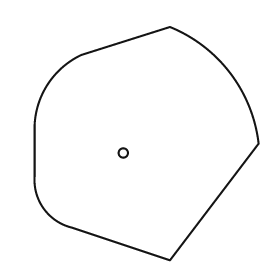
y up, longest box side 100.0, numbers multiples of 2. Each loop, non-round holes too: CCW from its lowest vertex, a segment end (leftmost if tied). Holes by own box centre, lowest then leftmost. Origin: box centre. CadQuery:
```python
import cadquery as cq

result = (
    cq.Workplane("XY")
    .moveTo(10.0, -50.0)
    .lineTo(48.0, 0.0)
    .threePointArc((36.0, 30.0), (10.0, 50.0))
    .lineTo(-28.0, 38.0)
    .threePointArc((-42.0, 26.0), (-48.0, 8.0))
    .lineTo(-48.0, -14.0)
    .threePointArc((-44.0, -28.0), (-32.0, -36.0))
    .close()
    .moveTo(-10.0, -4.0)
    .circle(2.0)
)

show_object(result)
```